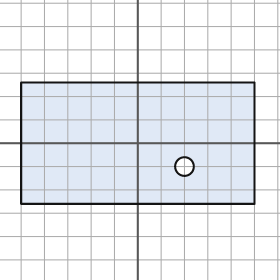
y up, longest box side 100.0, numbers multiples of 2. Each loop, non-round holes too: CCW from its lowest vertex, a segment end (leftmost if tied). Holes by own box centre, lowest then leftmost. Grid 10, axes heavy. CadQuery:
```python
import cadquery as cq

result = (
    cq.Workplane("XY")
    .moveTo(-50.0, -26.0)
    .lineTo(50.0, -26.0)
    .lineTo(50.0, 26.0)
    .lineTo(-50.0, 26.0)
    .close()
    .moveTo(20.0, -10.0)
    .circle(4.0)
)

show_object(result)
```